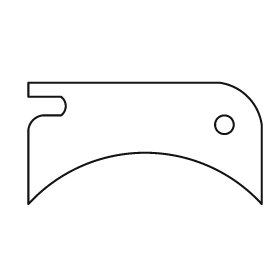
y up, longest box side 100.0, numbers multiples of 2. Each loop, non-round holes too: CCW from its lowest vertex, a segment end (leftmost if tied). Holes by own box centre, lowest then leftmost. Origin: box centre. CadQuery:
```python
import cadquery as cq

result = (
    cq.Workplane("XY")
    .moveTo(-50.0, -26.0)
    .threePointArc((0.0, -4.0), (50.0, -26.0))
    .lineTo(50.0, 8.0)
    .threePointArc((44.0, 20.0), (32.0, 26.0))
    .lineTo(-50.0, 26.0)
    .lineTo(-50.0, 20.0)
    .lineTo(-36.0, 20.0)
    .threePointArc((-34.0, 16.0), (-36.0, 12.0))
    .lineTo(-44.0, 12.0)
    .threePointArc((-48.0, 10.0), (-50.0, 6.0))
    .close()
    .moveTo(34.0, 8.0)
    .circle(4.0)
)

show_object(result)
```